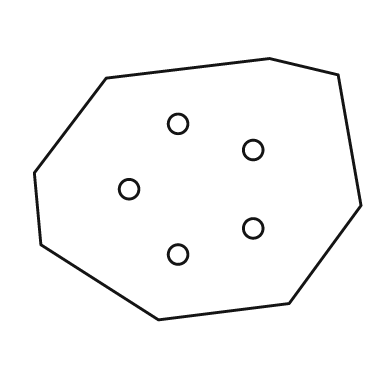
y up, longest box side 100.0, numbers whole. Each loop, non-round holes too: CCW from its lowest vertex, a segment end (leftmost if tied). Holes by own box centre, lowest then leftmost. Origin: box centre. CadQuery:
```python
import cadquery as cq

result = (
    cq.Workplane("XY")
    .moveTo(-12.0, -40.0)
    .lineTo(28.0, -35.0)
    .lineTo(50.0, -5.0)
    .lineTo(43.0, 35.0)
    .lineTo(22.0, 40.0)
    .lineTo(-28.0, 34.0)
    .lineTo(-50.0, 5.0)
    .lineTo(-48.0, -17.0)
    .close()
    .moveTo(-6.0, -20.0)
    .circle(3.0)
    .moveTo(17.0, -12.0)
    .circle(3.0)
    .moveTo(-21.0, 0.0)
    .circle(3.0)
    .moveTo(17.0, 12.0)
    .circle(3.0)
    .moveTo(-6.0, 20.0)
    .circle(3.0)
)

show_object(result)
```